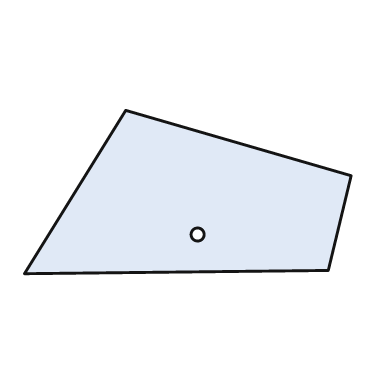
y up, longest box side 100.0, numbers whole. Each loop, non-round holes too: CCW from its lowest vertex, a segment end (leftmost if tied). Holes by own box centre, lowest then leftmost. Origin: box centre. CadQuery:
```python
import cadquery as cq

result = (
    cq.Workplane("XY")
    .moveTo(-50.0, -25.0)
    .lineTo(43.0, -24.0)
    .lineTo(50.0, 5.0)
    .lineTo(-19.0, 25.0)
    .close()
    .moveTo(3.0, -13.0)
    .circle(2.0)
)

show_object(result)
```